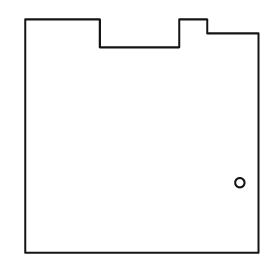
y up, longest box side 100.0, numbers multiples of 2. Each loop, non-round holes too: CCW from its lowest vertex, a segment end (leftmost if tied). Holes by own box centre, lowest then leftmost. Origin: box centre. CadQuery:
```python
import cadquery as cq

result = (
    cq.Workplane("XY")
    .moveTo(-50.0, -50.0)
    .lineTo(50.0, -50.0)
    .lineTo(50.0, 44.0)
    .lineTo(28.0, 44.0)
    .lineTo(28.0, 50.0)
    .lineTo(16.0, 50.0)
    .lineTo(16.0, 38.0)
    .lineTo(-18.0, 38.0)
    .lineTo(-18.0, 50.0)
    .lineTo(-50.0, 50.0)
    .close()
    .moveTo(42.0, -20.0)
    .circle(2.0)
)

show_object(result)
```